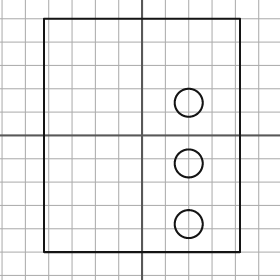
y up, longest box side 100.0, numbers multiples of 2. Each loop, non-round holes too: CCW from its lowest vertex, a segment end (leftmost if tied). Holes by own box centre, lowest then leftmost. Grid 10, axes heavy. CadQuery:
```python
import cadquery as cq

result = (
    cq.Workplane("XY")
    .moveTo(-42.0, -50.0)
    .lineTo(42.0, -50.0)
    .lineTo(42.0, 50.0)
    .lineTo(-42.0, 50.0)
    .close()
    .moveTo(20.0, -38.0)
    .circle(6.0)
    .moveTo(20.0, -12.0)
    .circle(6.0)
    .moveTo(20.0, 14.0)
    .circle(6.0)
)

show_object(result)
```